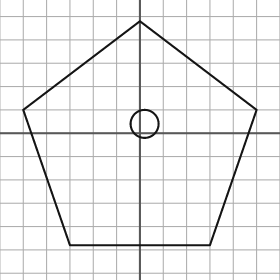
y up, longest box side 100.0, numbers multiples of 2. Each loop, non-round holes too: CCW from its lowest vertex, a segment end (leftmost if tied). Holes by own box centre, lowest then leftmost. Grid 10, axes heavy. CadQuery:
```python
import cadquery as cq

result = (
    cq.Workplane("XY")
    .moveTo(-30.0, -48.0)
    .lineTo(30.0, -48.0)
    .lineTo(50.0, 10.0)
    .lineTo(0.0, 48.0)
    .lineTo(-50.0, 10.0)
    .close()
    .moveTo(2.0, 4.0)
    .circle(6.0)
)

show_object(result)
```